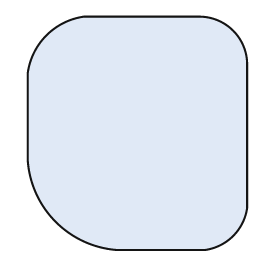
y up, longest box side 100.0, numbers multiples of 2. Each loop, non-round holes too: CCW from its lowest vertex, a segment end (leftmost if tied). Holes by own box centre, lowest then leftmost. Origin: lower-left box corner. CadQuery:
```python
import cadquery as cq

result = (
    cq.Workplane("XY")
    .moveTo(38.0, 0.0)
    .lineTo(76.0, 0.0)
    .threePointArc((88.0, 6.0), (94.0, 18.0))
    .lineTo(94.0, 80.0)
    .threePointArc((88.0, 94.0), (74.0, 100.0))
    .lineTo(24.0, 100.0)
    .threePointArc((8.0, 92.0), (0.0, 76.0))
    .lineTo(0.0, 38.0)
    .threePointArc((12.0, 12.0), (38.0, 0.0))
    .close()
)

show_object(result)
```